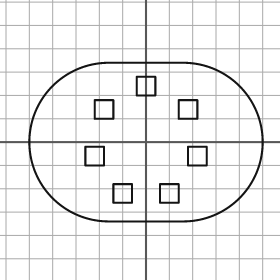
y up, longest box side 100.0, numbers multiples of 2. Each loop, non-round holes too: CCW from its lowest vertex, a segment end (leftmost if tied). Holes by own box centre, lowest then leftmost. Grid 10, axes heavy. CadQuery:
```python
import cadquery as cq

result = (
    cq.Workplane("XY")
    .moveTo(-16.0, -34.0)
    .lineTo(16.0, -34.0)
    .threePointArc((50.0, 0.0), (16.0, 34.0))
    .lineTo(-16.0, 34.0)
    .threePointArc((-50.0, 0.0), (-16.0, -34.0))
    .close()
    .moveTo(-14.0, -26.0)
    .lineTo(-6.0, -26.0)
    .lineTo(-6.0, -18.0)
    .lineTo(-14.0, -18.0)
    .close()
    .moveTo(6.0, -26.0)
    .lineTo(14.0, -26.0)
    .lineTo(14.0, -18.0)
    .lineTo(6.0, -18.0)
    .close()
    .moveTo(-26.0, -10.0)
    .lineTo(-18.0, -10.0)
    .lineTo(-18.0, -2.0)
    .lineTo(-26.0, -2.0)
    .close()
    .moveTo(18.0, -10.0)
    .lineTo(26.0, -10.0)
    .lineTo(26.0, -2.0)
    .lineTo(18.0, -2.0)
    .close()
    .moveTo(-22.0, 10.0)
    .lineTo(-14.0, 10.0)
    .lineTo(-14.0, 18.0)
    .lineTo(-22.0, 18.0)
    .close()
    .moveTo(14.0, 10.0)
    .lineTo(22.0, 10.0)
    .lineTo(22.0, 18.0)
    .lineTo(14.0, 18.0)
    .close()
    .moveTo(-4.0, 20.0)
    .lineTo(4.0, 20.0)
    .lineTo(4.0, 28.0)
    .lineTo(-4.0, 28.0)
    .close()
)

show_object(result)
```